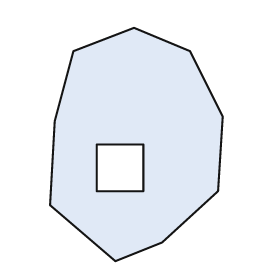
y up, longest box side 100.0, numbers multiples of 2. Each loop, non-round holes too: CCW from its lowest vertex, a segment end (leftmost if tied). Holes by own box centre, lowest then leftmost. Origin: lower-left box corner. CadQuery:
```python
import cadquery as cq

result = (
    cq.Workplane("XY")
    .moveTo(28.0, 0.0)
    .lineTo(48.0, 8.0)
    .lineTo(72.0, 30.0)
    .lineTo(74.0, 62.0)
    .lineTo(60.0, 90.0)
    .lineTo(36.0, 100.0)
    .lineTo(10.0, 90.0)
    .lineTo(2.0, 60.0)
    .lineTo(0.0, 24.0)
    .close()
    .moveTo(20.0, 30.0)
    .lineTo(40.0, 30.0)
    .lineTo(40.0, 50.0)
    .lineTo(20.0, 50.0)
    .close()
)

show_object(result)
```